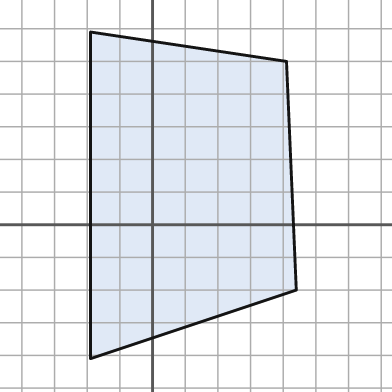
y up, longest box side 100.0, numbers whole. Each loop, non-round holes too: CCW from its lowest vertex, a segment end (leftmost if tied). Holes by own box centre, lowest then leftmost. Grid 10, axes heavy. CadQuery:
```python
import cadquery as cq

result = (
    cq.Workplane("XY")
    .moveTo(-19.0, -41.0)
    .lineTo(44.0, -20.0)
    .lineTo(41.0, 50.0)
    .lineTo(-19.0, 59.0)
    .close()
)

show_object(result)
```